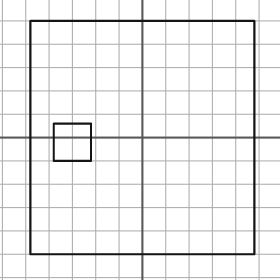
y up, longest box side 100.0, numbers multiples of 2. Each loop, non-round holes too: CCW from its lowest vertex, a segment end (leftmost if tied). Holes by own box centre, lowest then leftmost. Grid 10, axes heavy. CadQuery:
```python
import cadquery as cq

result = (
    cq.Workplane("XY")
    .moveTo(-48.0, -50.0)
    .lineTo(48.0, -50.0)
    .lineTo(48.0, 50.0)
    .lineTo(-48.0, 50.0)
    .close()
    .moveTo(-38.0, -10.0)
    .lineTo(-22.0, -10.0)
    .lineTo(-22.0, 6.0)
    .lineTo(-38.0, 6.0)
    .close()
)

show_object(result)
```